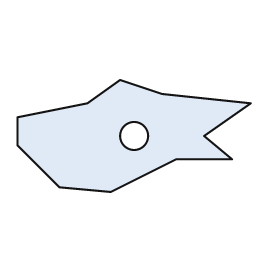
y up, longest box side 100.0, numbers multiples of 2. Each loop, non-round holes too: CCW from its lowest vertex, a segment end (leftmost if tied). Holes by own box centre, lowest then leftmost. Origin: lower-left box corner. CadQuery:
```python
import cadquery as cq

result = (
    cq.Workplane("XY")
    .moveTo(40.0, 0.0)
    .lineTo(68.0, 14.0)
    .lineTo(92.0, 14.0)
    .lineTo(80.0, 24.0)
    .lineTo(100.0, 38.0)
    .lineTo(62.0, 42.0)
    .lineTo(44.0, 48.0)
    .lineTo(30.0, 38.0)
    .lineTo(0.0, 32.0)
    .lineTo(0.0, 20.0)
    .lineTo(18.0, 2.0)
    .close()
    .moveTo(50.0, 24.0)
    .circle(6.0)
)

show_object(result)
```